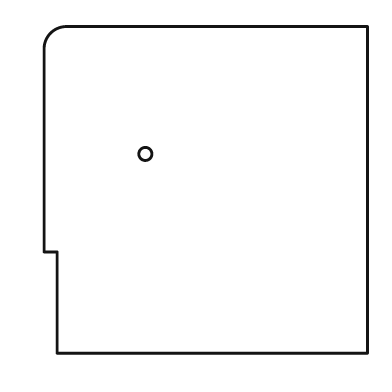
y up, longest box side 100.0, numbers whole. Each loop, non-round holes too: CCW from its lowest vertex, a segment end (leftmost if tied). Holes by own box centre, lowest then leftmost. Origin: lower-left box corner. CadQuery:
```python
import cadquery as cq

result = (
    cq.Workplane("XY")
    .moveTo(4.0, 0.0)
    .lineTo(99.0, 0.0)
    .lineTo(99.0, 100.0)
    .lineTo(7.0, 100.0)
    .threePointArc((2.0, 98.0), (0.0, 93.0))
    .lineTo(0.0, 31.0)
    .lineTo(4.0, 31.0)
    .close()
    .moveTo(31.0, 61.0)
    .circle(2.0)
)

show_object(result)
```